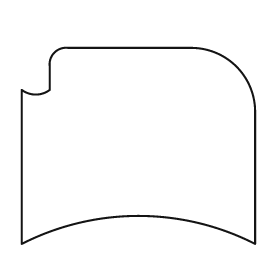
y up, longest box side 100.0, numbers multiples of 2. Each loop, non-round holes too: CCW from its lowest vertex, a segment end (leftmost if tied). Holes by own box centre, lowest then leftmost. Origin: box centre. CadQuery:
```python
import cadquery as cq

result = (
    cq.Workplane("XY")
    .moveTo(-50.0, -42.0)
    .threePointArc((0.0, -30.0), (50.0, -42.0))
    .lineTo(50.0, 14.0)
    .threePointArc((42.0, 34.0), (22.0, 42.0))
    .lineTo(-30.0, 42.0)
    .threePointArc((-36.0, 40.0), (-38.0, 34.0))
    .lineTo(-38.0, 24.0)
    .threePointArc((-44.0, 22.0), (-50.0, 24.0))
    .close()
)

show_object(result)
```